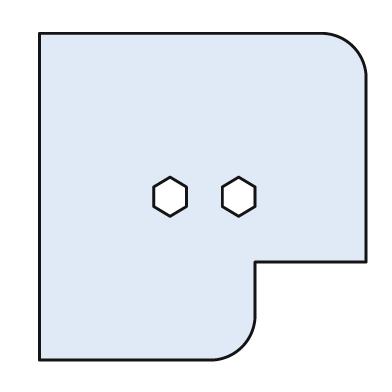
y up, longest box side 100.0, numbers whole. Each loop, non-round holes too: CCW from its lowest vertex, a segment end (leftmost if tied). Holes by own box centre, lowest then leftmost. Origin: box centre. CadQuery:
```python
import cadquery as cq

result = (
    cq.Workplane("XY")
    .moveTo(-50.0, -50.0)
    .lineTo(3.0, -50.0)
    .threePointArc((12.0, -46.0), (16.0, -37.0))
    .lineTo(16.0, -20.0)
    .lineTo(50.0, -20.0)
    .lineTo(50.0, 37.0)
    .threePointArc((46.0, 46.0), (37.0, 50.0))
    .lineTo(-50.0, 50.0)
    .close()
    .moveTo(-10.0, -6.0)
    .lineTo(-5.0, -3.0)
    .lineTo(-5.0, 3.0)
    .lineTo(-10.0, 6.0)
    .lineTo(-15.0, 3.0)
    .lineTo(-15.0, -3.0)
    .close()
    .moveTo(11.0, -6.0)
    .lineTo(16.0, -3.0)
    .lineTo(16.0, 3.0)
    .lineTo(11.0, 6.0)
    .lineTo(6.0, 3.0)
    .lineTo(6.0, -3.0)
    .close()
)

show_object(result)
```